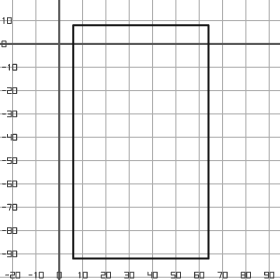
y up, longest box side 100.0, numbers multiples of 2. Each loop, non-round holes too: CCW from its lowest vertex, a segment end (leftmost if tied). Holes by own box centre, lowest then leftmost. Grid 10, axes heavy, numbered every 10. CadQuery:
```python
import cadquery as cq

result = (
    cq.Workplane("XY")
    .moveTo(6.0, -92.0)
    .lineTo(64.0, -92.0)
    .lineTo(64.0, 8.0)
    .lineTo(6.0, 8.0)
    .close()
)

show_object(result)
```